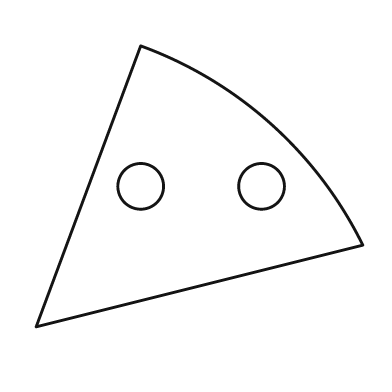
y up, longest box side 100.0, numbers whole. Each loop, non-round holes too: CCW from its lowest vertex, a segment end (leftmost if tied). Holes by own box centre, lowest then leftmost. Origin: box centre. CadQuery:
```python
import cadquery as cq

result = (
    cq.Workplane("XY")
    .moveTo(-50.0, -43.0)
    .lineTo(50.0, -18.0)
    .threePointArc((22.0, 19.0), (-18.0, 43.0))
    .close()
    .moveTo(-18.0, 0.0)
    .circle(7.0)
    .moveTo(19.0, 0.0)
    .circle(7.0)
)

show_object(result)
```